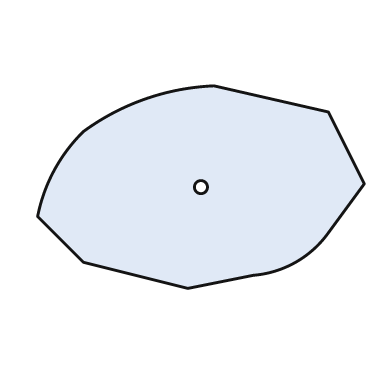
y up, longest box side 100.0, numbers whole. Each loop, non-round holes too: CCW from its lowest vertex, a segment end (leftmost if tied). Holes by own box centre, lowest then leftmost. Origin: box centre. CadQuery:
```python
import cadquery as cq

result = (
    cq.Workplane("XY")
    .moveTo(-4.0, -31.0)
    .lineTo(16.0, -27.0)
    .threePointArc((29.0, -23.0), (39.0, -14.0))
    .lineTo(50.0, 1.0)
    .lineTo(39.0, 23.0)
    .lineTo(4.0, 31.0)
    .threePointArc((-17.0, 27.0), (-36.0, 17.0))
    .threePointArc((-45.0, 5.0), (-50.0, -9.0))
    .lineTo(-36.0, -23.0)
    .close()
    .moveTo(0.0, 0.0)
    .circle(2.0)
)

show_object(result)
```